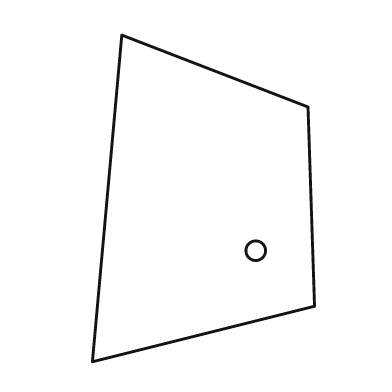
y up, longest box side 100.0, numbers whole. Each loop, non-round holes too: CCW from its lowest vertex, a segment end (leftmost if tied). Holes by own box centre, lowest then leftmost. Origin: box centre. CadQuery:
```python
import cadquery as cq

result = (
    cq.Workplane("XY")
    .moveTo(-34.0, -50.0)
    .lineTo(34.0, -33.0)
    .lineTo(32.0, 28.0)
    .lineTo(-25.0, 50.0)
    .close()
    .moveTo(16.0, -16.0)
    .circle(3.0)
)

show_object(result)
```